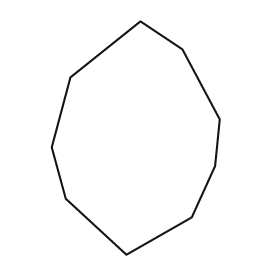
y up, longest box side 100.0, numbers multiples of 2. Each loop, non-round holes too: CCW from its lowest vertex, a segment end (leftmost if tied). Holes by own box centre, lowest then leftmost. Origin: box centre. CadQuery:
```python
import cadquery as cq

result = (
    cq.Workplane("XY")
    .moveTo(-4.0, -50.0)
    .lineTo(24.0, -34.0)
    .lineTo(34.0, -12.0)
    .lineTo(36.0, 8.0)
    .lineTo(20.0, 38.0)
    .lineTo(2.0, 50.0)
    .lineTo(-28.0, 26.0)
    .lineTo(-36.0, -4.0)
    .lineTo(-30.0, -26.0)
    .close()
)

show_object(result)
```